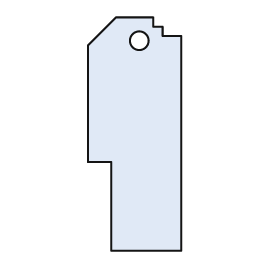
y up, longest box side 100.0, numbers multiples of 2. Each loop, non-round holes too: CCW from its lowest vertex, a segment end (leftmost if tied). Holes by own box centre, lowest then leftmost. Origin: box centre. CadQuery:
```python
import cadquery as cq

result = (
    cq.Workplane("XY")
    .moveTo(-10.0, -50.0)
    .lineTo(20.0, -50.0)
    .lineTo(20.0, 42.0)
    .lineTo(12.0, 42.0)
    .lineTo(12.0, 46.0)
    .lineTo(8.0, 46.0)
    .lineTo(8.0, 50.0)
    .lineTo(-8.0, 50.0)
    .lineTo(-20.0, 38.0)
    .lineTo(-20.0, -12.0)
    .lineTo(-10.0, -12.0)
    .close()
    .moveTo(2.0, 40.0)
    .circle(4.0)
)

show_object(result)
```